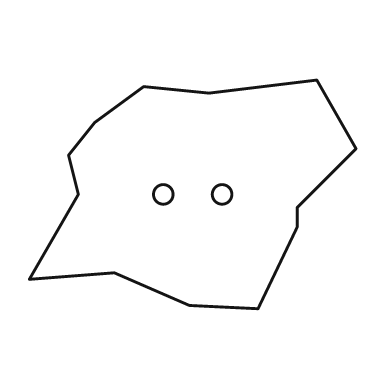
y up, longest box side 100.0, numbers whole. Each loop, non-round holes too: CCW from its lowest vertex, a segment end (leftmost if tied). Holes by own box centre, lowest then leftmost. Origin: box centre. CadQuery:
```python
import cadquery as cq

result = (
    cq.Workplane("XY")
    .moveTo(20.0, -35.0)
    .lineTo(32.0, -10.0)
    .lineTo(32.0, -4.0)
    .lineTo(50.0, 14.0)
    .lineTo(38.0, 35.0)
    .lineTo(5.0, 31.0)
    .lineTo(-15.0, 33.0)
    .lineTo(-30.0, 22.0)
    .lineTo(-38.0, 12.0)
    .lineTo(-35.0, 0.0)
    .lineTo(-50.0, -26.0)
    .lineTo(-24.0, -24.0)
    .lineTo(-1.0, -34.0)
    .close()
    .moveTo(-9.0, 0.0)
    .circle(3.0)
    .moveTo(9.0, 0.0)
    .circle(3.0)
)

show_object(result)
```